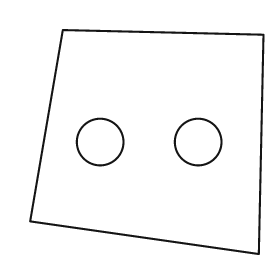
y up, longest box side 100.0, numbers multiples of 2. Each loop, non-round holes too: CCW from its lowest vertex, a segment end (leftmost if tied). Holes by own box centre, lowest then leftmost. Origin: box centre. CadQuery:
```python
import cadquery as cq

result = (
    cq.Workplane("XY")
    .moveTo(48.0, -48.0)
    .lineTo(50.0, 46.0)
    .lineTo(-36.0, 48.0)
    .lineTo(-50.0, -34.0)
    .close()
    .moveTo(-20.0, 0.0)
    .circle(10.0)
    .moveTo(22.0, 0.0)
    .circle(10.0)
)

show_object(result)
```